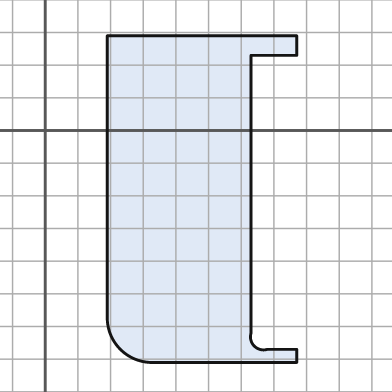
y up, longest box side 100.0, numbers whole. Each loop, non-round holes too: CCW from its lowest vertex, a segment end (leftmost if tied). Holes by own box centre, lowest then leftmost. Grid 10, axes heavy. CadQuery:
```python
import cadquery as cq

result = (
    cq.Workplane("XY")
    .moveTo(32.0, -71.0)
    .lineTo(77.0, -71.0)
    .lineTo(77.0, -67.0)
    .lineTo(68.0, -67.0)
    .threePointArc((64.0, -66.0), (63.0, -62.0))
    .lineTo(63.0, 23.0)
    .lineTo(77.0, 23.0)
    .lineTo(77.0, 29.0)
    .lineTo(19.0, 29.0)
    .lineTo(19.0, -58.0)
    .threePointArc((23.0, -67.0), (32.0, -71.0))
    .close()
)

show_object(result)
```